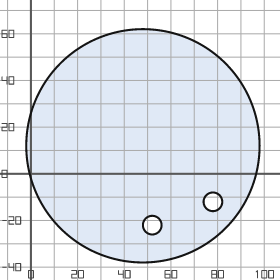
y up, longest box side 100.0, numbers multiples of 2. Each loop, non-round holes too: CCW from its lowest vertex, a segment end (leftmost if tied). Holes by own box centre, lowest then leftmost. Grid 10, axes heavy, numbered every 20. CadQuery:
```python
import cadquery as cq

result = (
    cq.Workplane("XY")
    .moveTo(48.0, 12.0)
    .circle(50.0)
    .moveTo(52.0, -22.0)
    .circle(4.0)
    .moveTo(78.0, -12.0)
    .circle(4.0)
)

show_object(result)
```